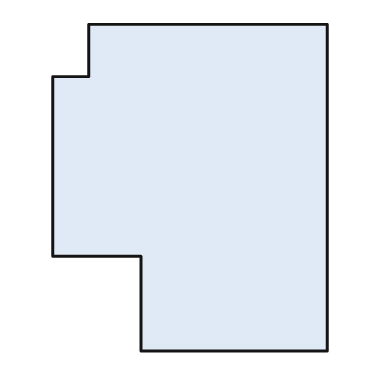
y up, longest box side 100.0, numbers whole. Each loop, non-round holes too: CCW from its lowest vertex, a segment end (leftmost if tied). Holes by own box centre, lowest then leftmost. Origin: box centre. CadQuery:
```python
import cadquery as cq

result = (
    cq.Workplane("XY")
    .moveTo(-15.0, -50.0)
    .lineTo(42.0, -50.0)
    .lineTo(42.0, 50.0)
    .lineTo(-31.0, 50.0)
    .lineTo(-31.0, 34.0)
    .lineTo(-42.0, 34.0)
    .lineTo(-42.0, -21.0)
    .lineTo(-15.0, -21.0)
    .close()
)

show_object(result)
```